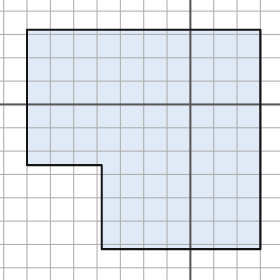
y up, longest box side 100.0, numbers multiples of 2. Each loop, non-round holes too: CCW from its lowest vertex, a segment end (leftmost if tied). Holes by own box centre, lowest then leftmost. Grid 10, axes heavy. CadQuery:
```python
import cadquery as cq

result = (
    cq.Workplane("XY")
    .moveTo(-38.0, -62.0)
    .lineTo(30.0, -62.0)
    .lineTo(30.0, 32.0)
    .lineTo(-70.0, 32.0)
    .lineTo(-70.0, -26.0)
    .lineTo(-38.0, -26.0)
    .close()
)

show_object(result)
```